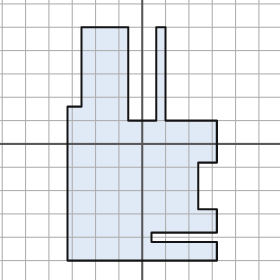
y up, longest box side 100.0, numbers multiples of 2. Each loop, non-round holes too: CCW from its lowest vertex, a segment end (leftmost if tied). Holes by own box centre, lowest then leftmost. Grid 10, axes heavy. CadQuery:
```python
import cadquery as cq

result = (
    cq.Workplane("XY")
    .moveTo(-32.0, -50.0)
    .lineTo(32.0, -50.0)
    .lineTo(32.0, -42.0)
    .lineTo(4.0, -42.0)
    .lineTo(4.0, -38.0)
    .lineTo(32.0, -38.0)
    .lineTo(32.0, -28.0)
    .lineTo(24.0, -28.0)
    .lineTo(24.0, -8.0)
    .lineTo(32.0, -8.0)
    .lineTo(32.0, 10.0)
    .lineTo(10.0, 10.0)
    .lineTo(10.0, 50.0)
    .lineTo(6.0, 50.0)
    .lineTo(6.0, 10.0)
    .lineTo(-6.0, 10.0)
    .lineTo(-6.0, 50.0)
    .lineTo(-26.0, 50.0)
    .lineTo(-26.0, 16.0)
    .lineTo(-32.0, 16.0)
    .close()
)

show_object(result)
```